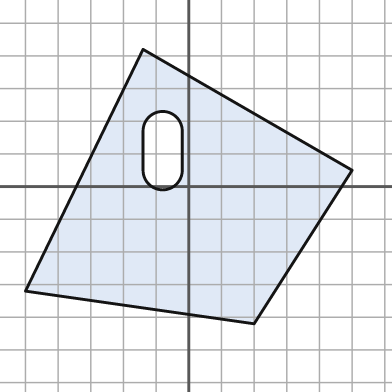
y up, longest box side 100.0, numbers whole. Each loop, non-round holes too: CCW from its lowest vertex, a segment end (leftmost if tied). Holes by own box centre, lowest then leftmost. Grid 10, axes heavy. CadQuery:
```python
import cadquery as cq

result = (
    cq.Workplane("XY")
    .moveTo(20.0, -42.0)
    .lineTo(50.0, 5.0)
    .lineTo(-14.0, 42.0)
    .lineTo(-50.0, -32.0)
    .close()
    .moveTo(-14.0, 5.0)
    .threePointArc((-8.0, -1.0), (-2.0, 5.0))
    .lineTo(-2.0, 17.0)
    .threePointArc((-8.0, 23.0), (-14.0, 17.0))
    .close()
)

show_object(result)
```